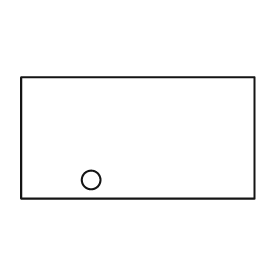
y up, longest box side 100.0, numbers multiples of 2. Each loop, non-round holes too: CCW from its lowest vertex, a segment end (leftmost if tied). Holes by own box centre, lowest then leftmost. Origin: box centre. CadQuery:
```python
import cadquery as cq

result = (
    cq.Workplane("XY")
    .moveTo(-50.0, -26.0)
    .lineTo(50.0, -26.0)
    .lineTo(50.0, 26.0)
    .lineTo(-50.0, 26.0)
    .close()
    .moveTo(-20.0, -18.0)
    .circle(4.0)
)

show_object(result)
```